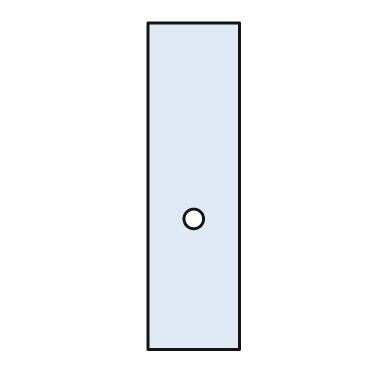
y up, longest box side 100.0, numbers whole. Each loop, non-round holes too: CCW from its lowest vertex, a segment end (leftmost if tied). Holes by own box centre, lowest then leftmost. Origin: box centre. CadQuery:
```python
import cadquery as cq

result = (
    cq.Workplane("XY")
    .moveTo(-14.0, -50.0)
    .lineTo(14.0, -50.0)
    .lineTo(14.0, 50.0)
    .lineTo(-14.0, 50.0)
    .close()
    .moveTo(0.0, -10.0)
    .circle(3.0)
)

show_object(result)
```